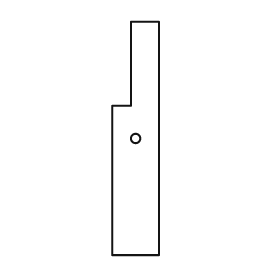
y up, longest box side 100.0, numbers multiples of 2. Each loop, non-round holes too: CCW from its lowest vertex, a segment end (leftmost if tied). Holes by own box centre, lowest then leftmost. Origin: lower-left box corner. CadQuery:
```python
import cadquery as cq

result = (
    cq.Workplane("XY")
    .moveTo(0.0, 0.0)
    .lineTo(20.0, 0.0)
    .lineTo(20.0, 100.0)
    .lineTo(8.0, 100.0)
    .lineTo(8.0, 64.0)
    .lineTo(0.0, 64.0)
    .close()
    .moveTo(10.0, 50.0)
    .circle(2.0)
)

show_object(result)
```